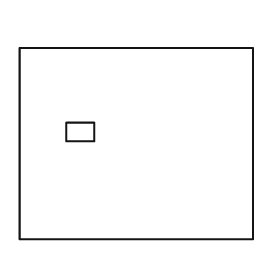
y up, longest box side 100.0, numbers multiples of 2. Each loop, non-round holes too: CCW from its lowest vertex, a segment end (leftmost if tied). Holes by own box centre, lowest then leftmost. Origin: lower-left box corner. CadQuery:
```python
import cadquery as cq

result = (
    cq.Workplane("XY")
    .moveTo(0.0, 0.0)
    .lineTo(100.0, 0.0)
    .lineTo(100.0, 82.0)
    .lineTo(0.0, 82.0)
    .close()
    .moveTo(20.0, 42.0)
    .lineTo(32.0, 42.0)
    .lineTo(32.0, 50.0)
    .lineTo(20.0, 50.0)
    .close()
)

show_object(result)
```